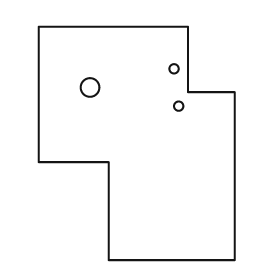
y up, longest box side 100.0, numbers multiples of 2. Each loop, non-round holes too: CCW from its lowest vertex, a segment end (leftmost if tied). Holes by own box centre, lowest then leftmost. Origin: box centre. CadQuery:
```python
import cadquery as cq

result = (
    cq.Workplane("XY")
    .moveTo(-12.0, -50.0)
    .lineTo(42.0, -50.0)
    .lineTo(42.0, 22.0)
    .lineTo(22.0, 22.0)
    .lineTo(22.0, 50.0)
    .lineTo(-42.0, 50.0)
    .lineTo(-42.0, -8.0)
    .lineTo(-12.0, -8.0)
    .close()
    .moveTo(18.0, 16.0)
    .circle(2.0)
    .moveTo(-20.0, 24.0)
    .circle(4.0)
    .moveTo(16.0, 32.0)
    .circle(2.0)
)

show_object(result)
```